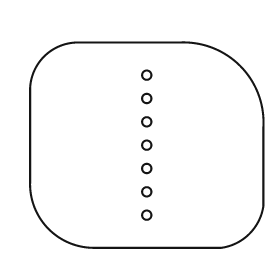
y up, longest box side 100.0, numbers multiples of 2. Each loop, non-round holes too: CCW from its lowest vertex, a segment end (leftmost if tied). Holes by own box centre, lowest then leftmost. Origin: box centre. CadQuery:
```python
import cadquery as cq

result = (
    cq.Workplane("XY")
    .moveTo(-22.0, -44.0)
    .lineTo(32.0, -44.0)
    .threePointArc((44.0, -38.0), (50.0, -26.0))
    .lineTo(50.0, 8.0)
    .threePointArc((40.0, 34.0), (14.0, 44.0))
    .lineTo(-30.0, 44.0)
    .threePointArc((-44.0, 38.0), (-50.0, 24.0))
    .lineTo(-50.0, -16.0)
    .threePointArc((-42.0, -36.0), (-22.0, -44.0))
    .close()
    .moveTo(0.0, -30.0)
    .circle(2.0)
    .moveTo(0.0, -20.0)
    .circle(2.0)
    .moveTo(0.0, -10.0)
    .circle(2.0)
    .moveTo(0.0, 0.0)
    .circle(2.0)
    .moveTo(0.0, 10.0)
    .circle(2.0)
    .moveTo(0.0, 20.0)
    .circle(2.0)
    .moveTo(0.0, 30.0)
    .circle(2.0)
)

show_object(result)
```